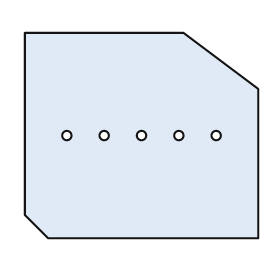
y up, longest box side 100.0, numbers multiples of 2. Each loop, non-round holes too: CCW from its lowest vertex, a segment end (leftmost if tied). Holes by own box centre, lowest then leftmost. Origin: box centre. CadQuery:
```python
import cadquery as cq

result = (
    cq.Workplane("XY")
    .moveTo(-40.0, -44.0)
    .lineTo(50.0, -44.0)
    .lineTo(50.0, 20.0)
    .lineTo(18.0, 44.0)
    .lineTo(-50.0, 44.0)
    .lineTo(-50.0, -34.0)
    .close()
    .moveTo(-32.0, 0.0)
    .circle(2.0)
    .moveTo(-16.0, 0.0)
    .circle(2.0)
    .moveTo(0.0, 0.0)
    .circle(2.0)
    .moveTo(16.0, 0.0)
    .circle(2.0)
    .moveTo(32.0, 0.0)
    .circle(2.0)
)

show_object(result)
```